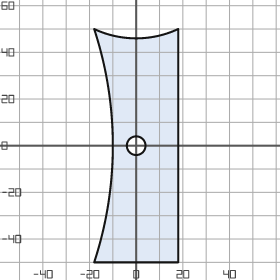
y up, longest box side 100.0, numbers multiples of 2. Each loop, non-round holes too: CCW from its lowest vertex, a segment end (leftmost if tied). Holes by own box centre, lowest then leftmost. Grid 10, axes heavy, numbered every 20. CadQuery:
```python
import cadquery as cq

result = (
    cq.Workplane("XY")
    .moveTo(-18.0, -50.0)
    .lineTo(18.0, -50.0)
    .lineTo(18.0, 50.0)
    .threePointArc((0.0, 46.0), (-18.0, 50.0))
    .threePointArc((-10.0, 0.0), (-18.0, -50.0))
    .close()
    .moveTo(0.0, 0.0)
    .circle(4.0)
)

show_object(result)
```